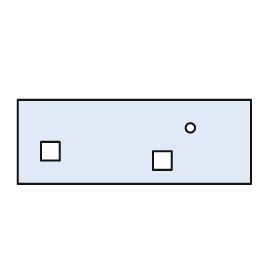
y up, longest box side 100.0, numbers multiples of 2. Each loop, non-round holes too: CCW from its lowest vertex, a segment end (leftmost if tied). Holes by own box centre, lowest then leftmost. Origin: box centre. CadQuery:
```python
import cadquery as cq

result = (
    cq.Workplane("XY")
    .moveTo(-50.0, -18.0)
    .lineTo(50.0, -18.0)
    .lineTo(50.0, 18.0)
    .lineTo(-50.0, 18.0)
    .close()
    .moveTo(8.0, -12.0)
    .lineTo(16.0, -12.0)
    .lineTo(16.0, -4.0)
    .lineTo(8.0, -4.0)
    .close()
    .moveTo(-40.0, -8.0)
    .lineTo(-32.0, -8.0)
    .lineTo(-32.0, 0.0)
    .lineTo(-40.0, 0.0)
    .close()
    .moveTo(24.0, 6.0)
    .circle(2.0)
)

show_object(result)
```